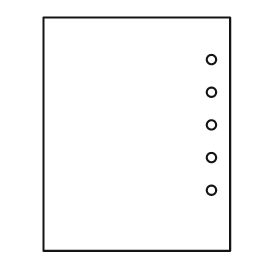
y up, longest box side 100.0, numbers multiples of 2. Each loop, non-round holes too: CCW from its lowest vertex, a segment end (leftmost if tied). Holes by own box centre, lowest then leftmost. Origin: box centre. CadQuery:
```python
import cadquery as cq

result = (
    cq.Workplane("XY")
    .moveTo(-40.0, -50.0)
    .lineTo(40.0, -50.0)
    .lineTo(40.0, 50.0)
    .lineTo(-40.0, 50.0)
    .close()
    .moveTo(32.0, -24.0)
    .circle(2.0)
    .moveTo(32.0, -10.0)
    .circle(2.0)
    .moveTo(32.0, 4.0)
    .circle(2.0)
    .moveTo(32.0, 18.0)
    .circle(2.0)
    .moveTo(32.0, 32.0)
    .circle(2.0)
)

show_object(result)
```